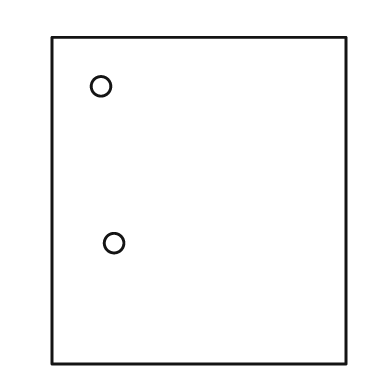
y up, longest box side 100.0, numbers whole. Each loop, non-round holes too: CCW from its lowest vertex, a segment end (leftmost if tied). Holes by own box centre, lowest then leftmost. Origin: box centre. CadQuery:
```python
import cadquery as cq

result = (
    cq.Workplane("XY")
    .moveTo(-45.0, -50.0)
    .lineTo(45.0, -50.0)
    .lineTo(45.0, 50.0)
    .lineTo(-45.0, 50.0)
    .close()
    .moveTo(-26.0, -13.0)
    .circle(3.0)
    .moveTo(-30.0, 35.0)
    .circle(3.0)
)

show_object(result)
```